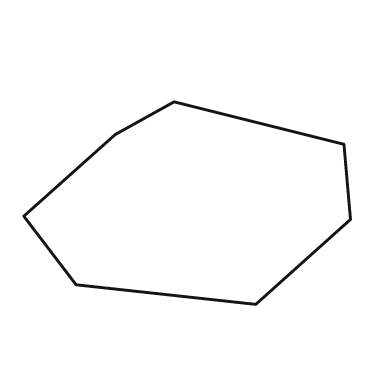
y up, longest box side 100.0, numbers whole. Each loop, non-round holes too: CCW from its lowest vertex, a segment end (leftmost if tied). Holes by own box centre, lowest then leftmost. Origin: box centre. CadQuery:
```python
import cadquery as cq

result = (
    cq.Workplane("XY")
    .moveTo(21.0, -31.0)
    .lineTo(50.0, -5.0)
    .lineTo(48.0, 18.0)
    .lineTo(-4.0, 31.0)
    .lineTo(-22.0, 21.0)
    .lineTo(-50.0, -4.0)
    .lineTo(-34.0, -25.0)
    .close()
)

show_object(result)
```